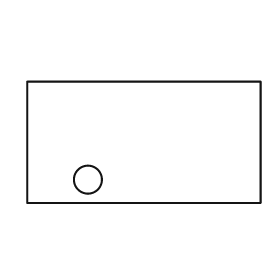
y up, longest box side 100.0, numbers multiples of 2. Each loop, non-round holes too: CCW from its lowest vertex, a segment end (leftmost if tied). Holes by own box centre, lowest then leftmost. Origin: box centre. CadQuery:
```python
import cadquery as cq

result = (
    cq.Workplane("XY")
    .moveTo(-50.0, -26.0)
    .lineTo(50.0, -26.0)
    .lineTo(50.0, 26.0)
    .lineTo(-50.0, 26.0)
    .close()
    .moveTo(-24.0, -16.0)
    .circle(6.0)
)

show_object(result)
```